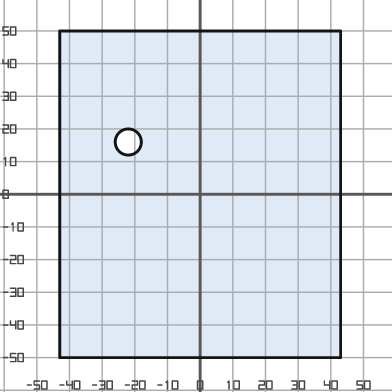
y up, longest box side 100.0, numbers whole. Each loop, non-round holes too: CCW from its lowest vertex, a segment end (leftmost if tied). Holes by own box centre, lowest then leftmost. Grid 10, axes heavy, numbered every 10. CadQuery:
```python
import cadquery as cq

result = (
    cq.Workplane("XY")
    .moveTo(-43.0, -50.0)
    .lineTo(43.0, -50.0)
    .lineTo(43.0, 50.0)
    .lineTo(-43.0, 50.0)
    .close()
    .moveTo(-22.0, 16.0)
    .circle(4.0)
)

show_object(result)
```